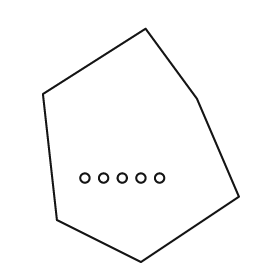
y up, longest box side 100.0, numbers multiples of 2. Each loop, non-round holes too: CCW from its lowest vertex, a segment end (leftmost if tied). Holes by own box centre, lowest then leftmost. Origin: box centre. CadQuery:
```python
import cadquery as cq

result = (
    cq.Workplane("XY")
    .moveTo(0.0, -50.0)
    .lineTo(42.0, -22.0)
    .lineTo(24.0, 20.0)
    .lineTo(2.0, 50.0)
    .lineTo(-42.0, 22.0)
    .lineTo(-36.0, -32.0)
    .close()
    .moveTo(-24.0, -14.0)
    .circle(2.0)
    .moveTo(-16.0, -14.0)
    .circle(2.0)
    .moveTo(-8.0, -14.0)
    .circle(2.0)
    .moveTo(0.0, -14.0)
    .circle(2.0)
    .moveTo(8.0, -14.0)
    .circle(2.0)
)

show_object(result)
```